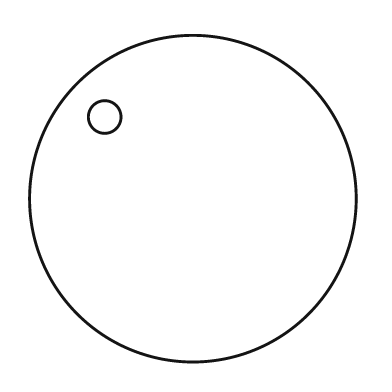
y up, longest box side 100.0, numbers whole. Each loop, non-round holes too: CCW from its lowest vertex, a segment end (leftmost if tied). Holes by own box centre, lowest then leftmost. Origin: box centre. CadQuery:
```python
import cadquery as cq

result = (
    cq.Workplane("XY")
    .moveTo(0.0, 0.0)
    .circle(50.0)
    .moveTo(-27.0, 25.0)
    .circle(5.0)
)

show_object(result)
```